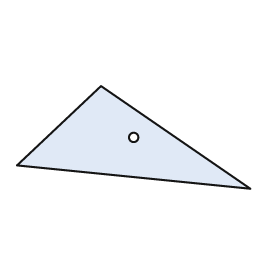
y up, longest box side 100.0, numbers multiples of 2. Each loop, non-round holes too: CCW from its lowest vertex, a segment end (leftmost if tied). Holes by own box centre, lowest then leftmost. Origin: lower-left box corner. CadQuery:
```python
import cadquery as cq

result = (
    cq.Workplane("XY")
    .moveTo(100.0, 0.0)
    .lineTo(36.0, 44.0)
    .lineTo(0.0, 10.0)
    .close()
    .moveTo(50.0, 22.0)
    .circle(2.0)
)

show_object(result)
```